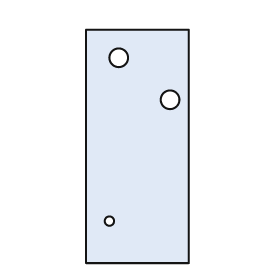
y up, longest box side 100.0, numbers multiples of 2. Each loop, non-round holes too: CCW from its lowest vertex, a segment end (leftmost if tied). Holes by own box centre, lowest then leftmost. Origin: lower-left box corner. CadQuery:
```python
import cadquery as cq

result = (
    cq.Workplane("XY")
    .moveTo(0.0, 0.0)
    .lineTo(44.0, 0.0)
    .lineTo(44.0, 100.0)
    .lineTo(0.0, 100.0)
    .close()
    .moveTo(10.0, 18.0)
    .circle(2.0)
    .moveTo(36.0, 70.0)
    .circle(4.0)
    .moveTo(14.0, 88.0)
    .circle(4.0)
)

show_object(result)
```